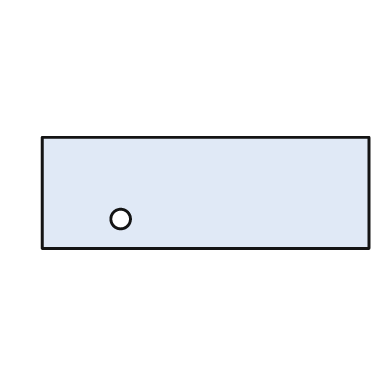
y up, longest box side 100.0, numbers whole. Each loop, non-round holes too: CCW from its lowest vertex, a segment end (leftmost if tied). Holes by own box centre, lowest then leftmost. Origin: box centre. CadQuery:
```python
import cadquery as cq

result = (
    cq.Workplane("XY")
    .moveTo(-50.0, -17.0)
    .lineTo(50.0, -17.0)
    .lineTo(50.0, 17.0)
    .lineTo(-50.0, 17.0)
    .close()
    .moveTo(-26.0, -8.0)
    .circle(3.0)
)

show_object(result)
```